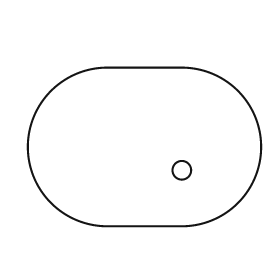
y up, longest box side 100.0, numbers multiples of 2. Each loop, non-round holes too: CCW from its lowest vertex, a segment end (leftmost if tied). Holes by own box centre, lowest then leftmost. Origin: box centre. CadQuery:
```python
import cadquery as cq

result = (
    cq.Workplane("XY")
    .moveTo(-16.0, -34.0)
    .lineTo(16.0, -34.0)
    .threePointArc((50.0, 0.0), (16.0, 34.0))
    .lineTo(-16.0, 34.0)
    .threePointArc((-50.0, 0.0), (-16.0, -34.0))
    .close()
    .moveTo(16.0, -10.0)
    .circle(4.0)
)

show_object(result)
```